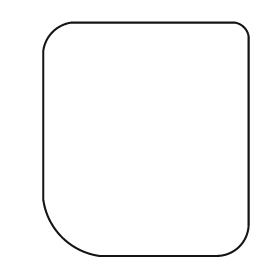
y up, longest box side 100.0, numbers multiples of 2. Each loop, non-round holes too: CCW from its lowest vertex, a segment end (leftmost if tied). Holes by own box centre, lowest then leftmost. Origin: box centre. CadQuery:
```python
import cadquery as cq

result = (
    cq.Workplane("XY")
    .moveTo(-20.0, -50.0)
    .lineTo(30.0, -50.0)
    .threePointArc((40.0, -46.0), (44.0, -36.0))
    .lineTo(44.0, 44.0)
    .threePointArc((42.0, 48.0), (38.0, 50.0))
    .lineTo(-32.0, 50.0)
    .threePointArc((-40.0, 46.0), (-44.0, 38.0))
    .lineTo(-44.0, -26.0)
    .threePointArc((-36.0, -42.0), (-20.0, -50.0))
    .close()
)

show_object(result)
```